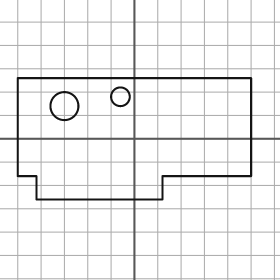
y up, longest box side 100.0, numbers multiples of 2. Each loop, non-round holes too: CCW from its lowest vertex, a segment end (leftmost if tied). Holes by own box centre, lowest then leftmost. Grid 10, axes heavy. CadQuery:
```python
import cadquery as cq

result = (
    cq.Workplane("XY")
    .moveTo(-42.0, -26.0)
    .lineTo(12.0, -26.0)
    .lineTo(12.0, -16.0)
    .lineTo(50.0, -16.0)
    .lineTo(50.0, 26.0)
    .lineTo(-50.0, 26.0)
    .lineTo(-50.0, -16.0)
    .lineTo(-42.0, -16.0)
    .close()
    .moveTo(-30.0, 14.0)
    .circle(6.0)
    .moveTo(-6.0, 18.0)
    .circle(4.0)
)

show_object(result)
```